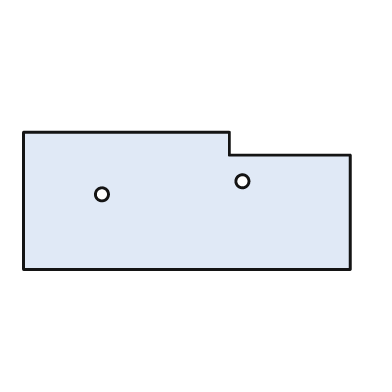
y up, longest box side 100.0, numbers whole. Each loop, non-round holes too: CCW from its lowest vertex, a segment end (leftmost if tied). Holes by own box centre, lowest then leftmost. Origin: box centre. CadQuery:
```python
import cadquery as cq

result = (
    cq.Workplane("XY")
    .moveTo(-50.0, -21.0)
    .lineTo(50.0, -21.0)
    .lineTo(50.0, 14.0)
    .lineTo(13.0, 14.0)
    .lineTo(13.0, 21.0)
    .lineTo(-50.0, 21.0)
    .close()
    .moveTo(-26.0, 2.0)
    .circle(2.0)
    .moveTo(17.0, 6.0)
    .circle(2.0)
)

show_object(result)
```